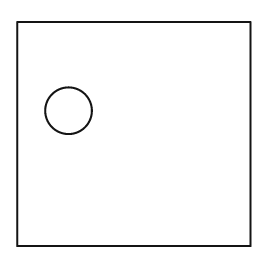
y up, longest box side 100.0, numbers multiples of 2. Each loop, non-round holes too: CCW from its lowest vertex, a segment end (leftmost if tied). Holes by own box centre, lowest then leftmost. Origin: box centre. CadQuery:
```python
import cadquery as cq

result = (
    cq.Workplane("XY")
    .moveTo(-50.0, -48.0)
    .lineTo(50.0, -48.0)
    .lineTo(50.0, 48.0)
    .lineTo(-50.0, 48.0)
    .close()
    .moveTo(-28.0, 10.0)
    .circle(10.0)
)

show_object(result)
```